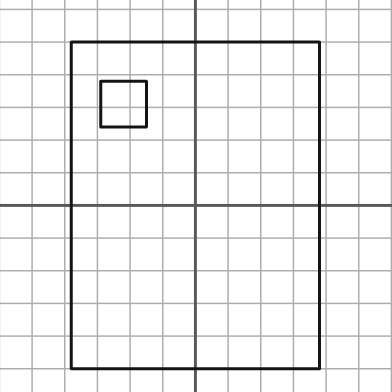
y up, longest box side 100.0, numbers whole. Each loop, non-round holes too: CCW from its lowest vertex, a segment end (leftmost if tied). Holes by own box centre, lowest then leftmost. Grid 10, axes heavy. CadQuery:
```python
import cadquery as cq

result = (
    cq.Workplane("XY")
    .moveTo(-38.0, -50.0)
    .lineTo(38.0, -50.0)
    .lineTo(38.0, 50.0)
    .lineTo(-38.0, 50.0)
    .close()
    .moveTo(-29.0, 24.0)
    .lineTo(-15.0, 24.0)
    .lineTo(-15.0, 38.0)
    .lineTo(-29.0, 38.0)
    .close()
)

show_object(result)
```